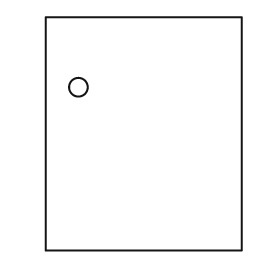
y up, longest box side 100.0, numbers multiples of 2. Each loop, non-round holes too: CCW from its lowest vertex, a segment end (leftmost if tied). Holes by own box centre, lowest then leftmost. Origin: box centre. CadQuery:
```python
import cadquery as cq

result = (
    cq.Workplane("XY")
    .moveTo(-42.0, -50.0)
    .lineTo(42.0, -50.0)
    .lineTo(42.0, 50.0)
    .lineTo(-42.0, 50.0)
    .close()
    .moveTo(-28.0, 20.0)
    .circle(4.0)
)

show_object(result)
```